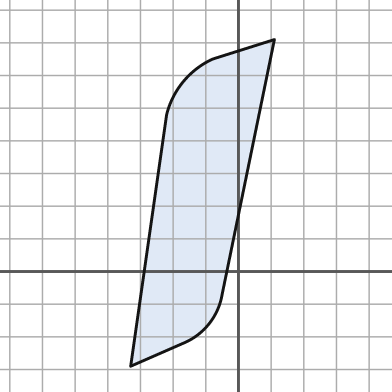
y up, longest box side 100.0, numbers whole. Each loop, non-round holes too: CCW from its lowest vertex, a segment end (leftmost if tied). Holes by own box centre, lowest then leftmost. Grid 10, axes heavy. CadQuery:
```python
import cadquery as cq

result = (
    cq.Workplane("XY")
    .moveTo(-33.0, -29.0)
    .lineTo(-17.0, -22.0)
    .threePointArc((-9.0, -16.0), (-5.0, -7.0))
    .lineTo(11.0, 71.0)
    .lineTo(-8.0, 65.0)
    .threePointArc((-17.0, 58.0), (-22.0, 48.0))
    .close()
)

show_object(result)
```